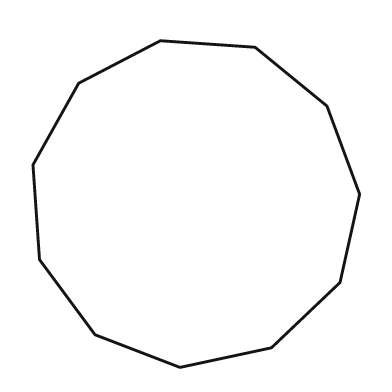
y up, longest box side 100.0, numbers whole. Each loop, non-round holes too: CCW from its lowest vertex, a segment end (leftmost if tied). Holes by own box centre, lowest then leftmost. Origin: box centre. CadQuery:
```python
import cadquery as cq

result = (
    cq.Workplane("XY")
    .moveTo(-5.0, -50.0)
    .lineTo(23.0, -44.0)
    .lineTo(44.0, -24.0)
    .lineTo(50.0, 3.0)
    .lineTo(40.0, 30.0)
    .lineTo(18.0, 48.0)
    .lineTo(-11.0, 50.0)
    .lineTo(-36.0, 37.0)
    .lineTo(-50.0, 12.0)
    .lineTo(-48.0, -17.0)
    .lineTo(-31.0, -40.0)
    .close()
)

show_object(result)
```